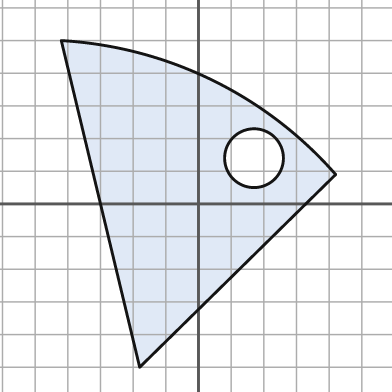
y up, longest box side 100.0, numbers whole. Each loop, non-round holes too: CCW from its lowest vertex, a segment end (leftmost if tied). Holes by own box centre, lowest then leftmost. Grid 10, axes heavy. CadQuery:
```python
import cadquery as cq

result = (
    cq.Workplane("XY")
    .moveTo(-18.0, -50.0)
    .lineTo(42.0, 9.0)
    .threePointArc((4.0, 38.0), (-42.0, 50.0))
    .close()
    .moveTo(17.0, 14.0)
    .circle(9.0)
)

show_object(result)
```